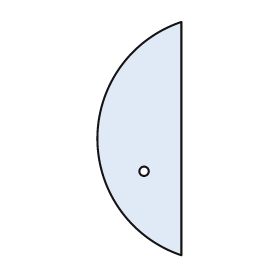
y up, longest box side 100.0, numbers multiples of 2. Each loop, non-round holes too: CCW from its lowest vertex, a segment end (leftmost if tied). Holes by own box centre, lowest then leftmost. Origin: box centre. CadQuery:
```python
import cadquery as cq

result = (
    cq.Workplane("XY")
    .moveTo(18.0, -50.0)
    .lineTo(18.0, 50.0)
    .threePointArc((-18.0, 0.0), (18.0, -50.0))
    .close()
    .moveTo(2.0, -14.0)
    .circle(2.0)
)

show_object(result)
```